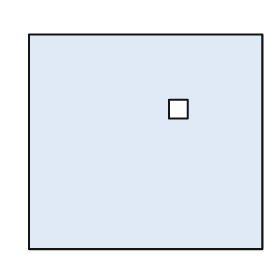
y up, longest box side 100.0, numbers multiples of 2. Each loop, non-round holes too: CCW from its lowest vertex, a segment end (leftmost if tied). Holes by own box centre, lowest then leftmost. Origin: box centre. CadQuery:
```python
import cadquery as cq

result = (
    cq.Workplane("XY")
    .moveTo(-50.0, -46.0)
    .lineTo(50.0, -46.0)
    .lineTo(50.0, 46.0)
    .lineTo(-50.0, 46.0)
    .close()
    .moveTo(10.0, 10.0)
    .lineTo(18.0, 10.0)
    .lineTo(18.0, 18.0)
    .lineTo(10.0, 18.0)
    .close()
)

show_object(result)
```